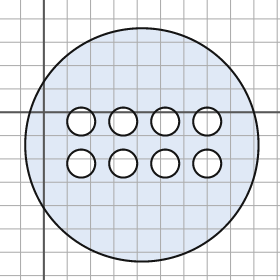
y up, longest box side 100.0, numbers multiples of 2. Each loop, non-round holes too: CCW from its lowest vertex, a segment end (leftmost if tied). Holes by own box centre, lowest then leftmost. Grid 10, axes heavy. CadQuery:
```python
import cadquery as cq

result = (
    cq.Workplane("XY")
    .moveTo(42.0, -14.0)
    .circle(50.0)
    .moveTo(16.0, -22.0)
    .circle(6.0)
    .moveTo(34.0, -22.0)
    .circle(6.0)
    .moveTo(52.0, -22.0)
    .circle(6.0)
    .moveTo(70.0, -22.0)
    .circle(6.0)
    .moveTo(16.0, -4.0)
    .circle(6.0)
    .moveTo(34.0, -4.0)
    .circle(6.0)
    .moveTo(52.0, -4.0)
    .circle(6.0)
    .moveTo(70.0, -4.0)
    .circle(6.0)
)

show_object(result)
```